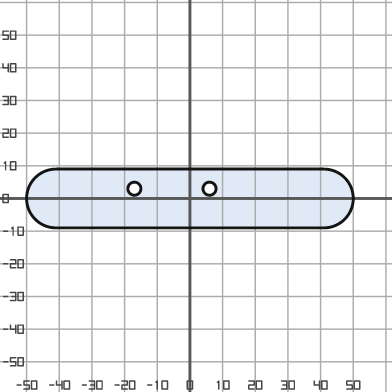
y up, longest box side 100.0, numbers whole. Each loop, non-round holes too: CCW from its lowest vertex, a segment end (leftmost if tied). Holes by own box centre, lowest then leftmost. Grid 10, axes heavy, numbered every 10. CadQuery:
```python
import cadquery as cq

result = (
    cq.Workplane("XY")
    .moveTo(-41.0, -9.0)
    .lineTo(41.0, -9.0)
    .threePointArc((50.0, 0.0), (41.0, 9.0))
    .lineTo(-41.0, 9.0)
    .threePointArc((-50.0, 0.0), (-41.0, -9.0))
    .close()
    .moveTo(-17.0, 3.0)
    .circle(2.0)
    .moveTo(6.0, 3.0)
    .circle(2.0)
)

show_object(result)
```